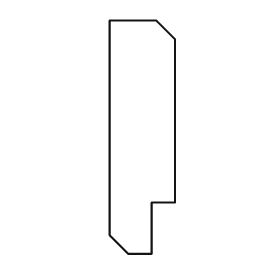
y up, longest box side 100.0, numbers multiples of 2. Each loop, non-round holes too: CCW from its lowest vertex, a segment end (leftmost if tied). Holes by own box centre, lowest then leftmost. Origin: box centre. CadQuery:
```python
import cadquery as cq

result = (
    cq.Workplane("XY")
    .moveTo(-6.0, -50.0)
    .lineTo(4.0, -50.0)
    .lineTo(4.0, -28.0)
    .lineTo(14.0, -28.0)
    .lineTo(14.0, 42.0)
    .lineTo(6.0, 50.0)
    .lineTo(-14.0, 50.0)
    .lineTo(-14.0, -42.0)
    .close()
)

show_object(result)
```